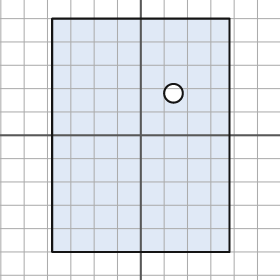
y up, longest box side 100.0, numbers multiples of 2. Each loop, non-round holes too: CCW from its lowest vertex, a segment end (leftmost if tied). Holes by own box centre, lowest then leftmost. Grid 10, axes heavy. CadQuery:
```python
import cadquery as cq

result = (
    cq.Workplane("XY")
    .moveTo(-38.0, -50.0)
    .lineTo(38.0, -50.0)
    .lineTo(38.0, 50.0)
    .lineTo(-38.0, 50.0)
    .close()
    .moveTo(14.0, 18.0)
    .circle(4.0)
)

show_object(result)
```